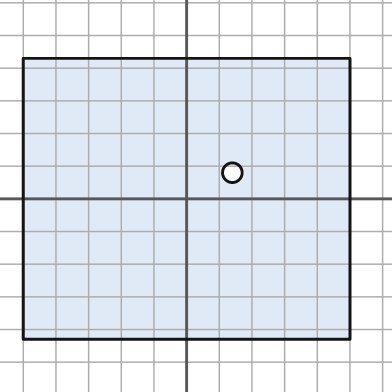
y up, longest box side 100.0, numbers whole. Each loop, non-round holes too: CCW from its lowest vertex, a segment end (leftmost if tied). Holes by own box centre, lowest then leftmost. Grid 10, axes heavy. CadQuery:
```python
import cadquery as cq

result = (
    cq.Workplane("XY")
    .moveTo(-50.0, -43.0)
    .lineTo(50.0, -43.0)
    .lineTo(50.0, 43.0)
    .lineTo(-50.0, 43.0)
    .close()
    .moveTo(14.0, 8.0)
    .circle(3.0)
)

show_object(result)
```